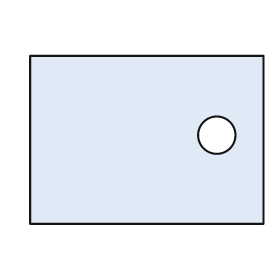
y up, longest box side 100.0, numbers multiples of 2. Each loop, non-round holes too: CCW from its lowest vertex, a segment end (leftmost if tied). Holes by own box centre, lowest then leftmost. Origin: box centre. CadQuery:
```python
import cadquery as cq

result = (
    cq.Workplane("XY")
    .moveTo(-50.0, -36.0)
    .lineTo(50.0, -36.0)
    .lineTo(50.0, 36.0)
    .lineTo(-50.0, 36.0)
    .close()
    .moveTo(30.0, 2.0)
    .circle(8.0)
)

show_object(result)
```